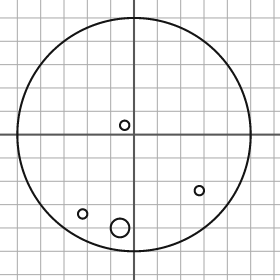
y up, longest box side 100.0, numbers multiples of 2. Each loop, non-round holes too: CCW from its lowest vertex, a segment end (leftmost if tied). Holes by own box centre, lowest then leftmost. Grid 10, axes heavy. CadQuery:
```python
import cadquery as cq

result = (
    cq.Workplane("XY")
    .moveTo(0.0, 0.0)
    .circle(50.0)
    .moveTo(-6.0, -40.0)
    .circle(4.0)
    .moveTo(-22.0, -34.0)
    .circle(2.0)
    .moveTo(28.0, -24.0)
    .circle(2.0)
    .moveTo(-4.0, 4.0)
    .circle(2.0)
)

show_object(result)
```